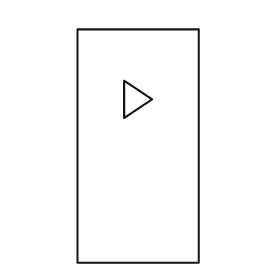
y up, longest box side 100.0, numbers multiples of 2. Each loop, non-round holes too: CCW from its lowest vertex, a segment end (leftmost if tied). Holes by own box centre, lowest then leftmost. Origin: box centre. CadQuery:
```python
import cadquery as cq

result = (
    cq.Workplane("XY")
    .moveTo(-26.0, -50.0)
    .lineTo(26.0, -50.0)
    .lineTo(26.0, 50.0)
    .lineTo(-26.0, 50.0)
    .close()
    .moveTo(-6.0, 12.0)
    .lineTo(6.0, 20.0)
    .lineTo(-6.0, 28.0)
    .close()
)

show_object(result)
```